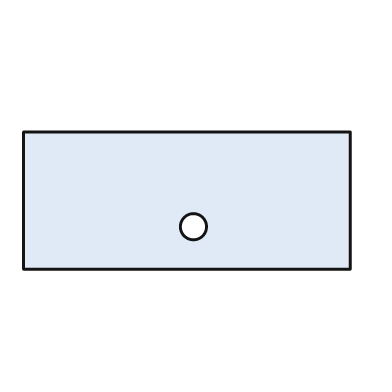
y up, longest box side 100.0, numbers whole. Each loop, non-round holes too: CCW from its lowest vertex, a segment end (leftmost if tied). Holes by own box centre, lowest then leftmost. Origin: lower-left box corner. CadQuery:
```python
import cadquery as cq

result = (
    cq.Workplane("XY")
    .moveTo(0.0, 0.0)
    .lineTo(100.0, 0.0)
    .lineTo(100.0, 42.0)
    .lineTo(0.0, 42.0)
    .close()
    .moveTo(52.0, 13.0)
    .circle(4.0)
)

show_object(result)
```